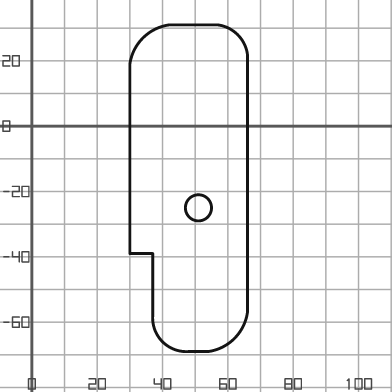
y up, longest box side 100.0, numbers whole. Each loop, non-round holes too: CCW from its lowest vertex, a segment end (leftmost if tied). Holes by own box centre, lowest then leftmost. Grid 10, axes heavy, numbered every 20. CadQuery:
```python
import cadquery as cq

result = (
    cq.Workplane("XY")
    .moveTo(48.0, -69.0)
    .lineTo(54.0, -69.0)
    .threePointArc((62.0, -65.0), (66.0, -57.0))
    .lineTo(66.0, 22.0)
    .threePointArc((63.0, 28.0), (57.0, 31.0))
    .lineTo(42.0, 31.0)
    .threePointArc((34.0, 27.0), (30.0, 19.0))
    .lineTo(30.0, -39.0)
    .lineTo(37.0, -39.0)
    .lineTo(37.0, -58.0)
    .threePointArc((40.0, -66.0), (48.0, -69.0))
    .close()
    .moveTo(51.0, -25.0)
    .circle(4.0)
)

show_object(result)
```